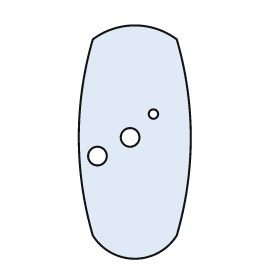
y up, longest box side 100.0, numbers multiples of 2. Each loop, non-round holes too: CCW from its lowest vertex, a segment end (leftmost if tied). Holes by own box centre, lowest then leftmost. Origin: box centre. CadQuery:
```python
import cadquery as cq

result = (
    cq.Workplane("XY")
    .moveTo(-18.0, -40.0)
    .threePointArc((0.0, -50.0), (18.0, -40.0))
    .threePointArc((24.0, 2.0), (18.0, 44.0))
    .threePointArc((0.0, 50.0), (-18.0, 44.0))
    .threePointArc((-24.0, 2.0), (-18.0, -40.0))
    .close()
    .moveTo(-16.0, -6.0)
    .circle(4.0)
    .moveTo(-2.0, 2.0)
    .circle(4.0)
    .moveTo(8.0, 12.0)
    .circle(2.0)
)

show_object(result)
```